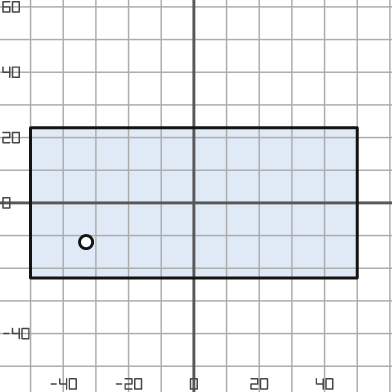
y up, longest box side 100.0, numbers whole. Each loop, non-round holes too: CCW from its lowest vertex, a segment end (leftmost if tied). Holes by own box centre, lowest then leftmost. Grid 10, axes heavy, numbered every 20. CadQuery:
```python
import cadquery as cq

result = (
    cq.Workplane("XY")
    .moveTo(-50.0, -23.0)
    .lineTo(50.0, -23.0)
    .lineTo(50.0, 23.0)
    .lineTo(-50.0, 23.0)
    .close()
    .moveTo(-33.0, -12.0)
    .circle(2.0)
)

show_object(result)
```